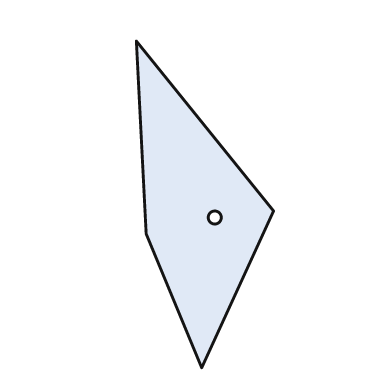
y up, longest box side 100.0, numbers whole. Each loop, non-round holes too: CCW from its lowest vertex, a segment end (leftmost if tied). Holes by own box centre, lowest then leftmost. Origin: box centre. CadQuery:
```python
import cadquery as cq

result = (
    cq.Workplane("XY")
    .moveTo(-1.0, -50.0)
    .lineTo(21.0, -2.0)
    .lineTo(-21.0, 50.0)
    .lineTo(-18.0, -9.0)
    .close()
    .moveTo(3.0, -4.0)
    .circle(2.0)
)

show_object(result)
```